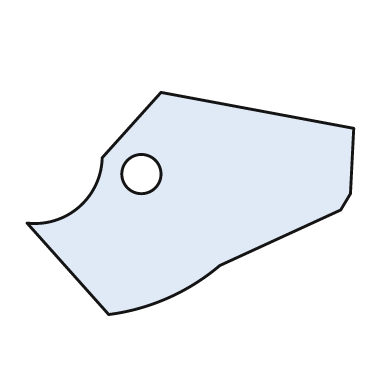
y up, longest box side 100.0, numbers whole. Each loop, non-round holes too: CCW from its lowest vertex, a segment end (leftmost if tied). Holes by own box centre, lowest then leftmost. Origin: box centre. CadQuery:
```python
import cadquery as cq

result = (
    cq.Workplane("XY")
    .moveTo(-25.0, -34.0)
    .threePointArc((-7.0, -29.0), (9.0, -19.0))
    .lineTo(46.0, -2.0)
    .lineTo(49.0, 3.0)
    .lineTo(50.0, 23.0)
    .lineTo(-9.0, 34.0)
    .lineTo(-27.0, 14.0)
    .threePointArc((-34.0, -1.0), (-50.0, -6.0))
    .close()
    .moveTo(-15.0, 9.0)
    .circle(6.0)
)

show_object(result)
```